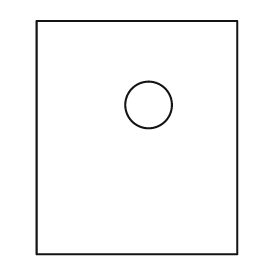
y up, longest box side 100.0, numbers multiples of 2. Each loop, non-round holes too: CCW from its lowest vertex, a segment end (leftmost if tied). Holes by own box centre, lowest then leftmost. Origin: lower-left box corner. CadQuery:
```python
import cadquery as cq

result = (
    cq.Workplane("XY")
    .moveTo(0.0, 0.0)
    .lineTo(86.0, 0.0)
    .lineTo(86.0, 100.0)
    .lineTo(0.0, 100.0)
    .close()
    .moveTo(48.0, 64.0)
    .circle(10.0)
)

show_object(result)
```